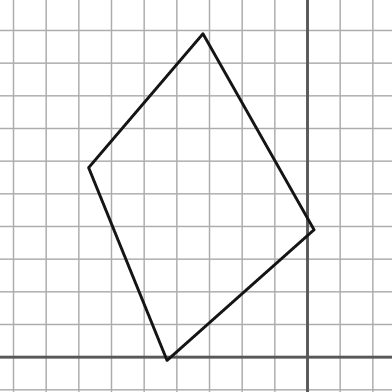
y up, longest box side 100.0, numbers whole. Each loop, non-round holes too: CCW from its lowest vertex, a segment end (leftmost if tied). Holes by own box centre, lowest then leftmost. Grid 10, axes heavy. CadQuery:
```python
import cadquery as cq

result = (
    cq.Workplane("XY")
    .moveTo(-43.0, -1.0)
    .lineTo(2.0, 39.0)
    .lineTo(-32.0, 99.0)
    .lineTo(-67.0, 58.0)
    .close()
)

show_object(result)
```